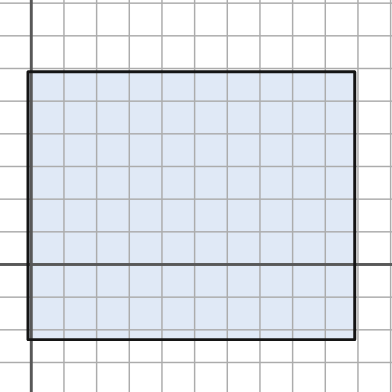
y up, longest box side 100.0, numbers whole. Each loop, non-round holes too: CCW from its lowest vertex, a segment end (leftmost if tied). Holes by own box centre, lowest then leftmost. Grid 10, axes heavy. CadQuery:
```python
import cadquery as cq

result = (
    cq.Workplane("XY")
    .moveTo(-1.0, -23.0)
    .lineTo(99.0, -23.0)
    .lineTo(99.0, 59.0)
    .lineTo(-1.0, 59.0)
    .close()
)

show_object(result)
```